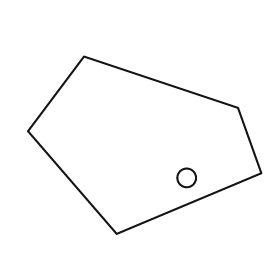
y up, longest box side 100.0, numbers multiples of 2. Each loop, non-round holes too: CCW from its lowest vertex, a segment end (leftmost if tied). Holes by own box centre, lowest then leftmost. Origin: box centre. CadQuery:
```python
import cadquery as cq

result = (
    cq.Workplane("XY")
    .moveTo(-12.0, -38.0)
    .lineTo(50.0, -12.0)
    .lineTo(40.0, 16.0)
    .lineTo(-26.0, 38.0)
    .lineTo(-50.0, 6.0)
    .close()
    .moveTo(18.0, -14.0)
    .circle(4.0)
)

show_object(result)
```